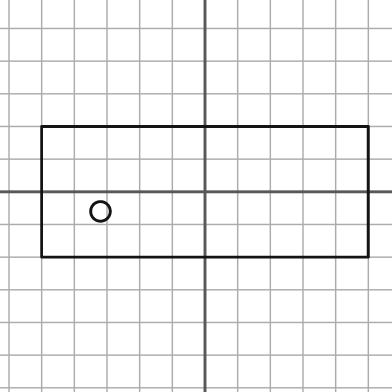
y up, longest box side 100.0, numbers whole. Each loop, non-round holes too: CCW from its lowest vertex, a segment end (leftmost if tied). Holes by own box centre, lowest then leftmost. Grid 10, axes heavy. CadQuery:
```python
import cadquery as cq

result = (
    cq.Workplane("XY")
    .moveTo(-50.0, -20.0)
    .lineTo(50.0, -20.0)
    .lineTo(50.0, 20.0)
    .lineTo(-50.0, 20.0)
    .close()
    .moveTo(-32.0, -6.0)
    .circle(3.0)
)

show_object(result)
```